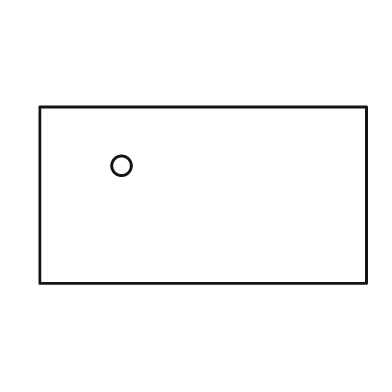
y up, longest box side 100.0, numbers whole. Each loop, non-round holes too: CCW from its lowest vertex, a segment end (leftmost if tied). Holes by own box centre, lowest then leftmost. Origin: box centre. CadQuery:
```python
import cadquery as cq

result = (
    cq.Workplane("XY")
    .moveTo(-50.0, -27.0)
    .lineTo(50.0, -27.0)
    .lineTo(50.0, 27.0)
    .lineTo(-50.0, 27.0)
    .close()
    .moveTo(-25.0, 9.0)
    .circle(3.0)
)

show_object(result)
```